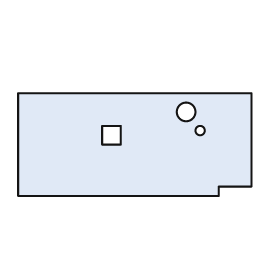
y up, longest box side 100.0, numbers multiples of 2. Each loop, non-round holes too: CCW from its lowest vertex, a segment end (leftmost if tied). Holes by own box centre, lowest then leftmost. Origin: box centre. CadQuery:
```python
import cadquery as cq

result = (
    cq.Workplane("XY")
    .moveTo(-50.0, -22.0)
    .lineTo(36.0, -22.0)
    .lineTo(36.0, -18.0)
    .lineTo(50.0, -18.0)
    .lineTo(50.0, 22.0)
    .lineTo(-50.0, 22.0)
    .close()
    .moveTo(-14.0, 0.0)
    .lineTo(-6.0, 0.0)
    .lineTo(-6.0, 8.0)
    .lineTo(-14.0, 8.0)
    .close()
    .moveTo(28.0, 6.0)
    .circle(2.0)
    .moveTo(22.0, 14.0)
    .circle(4.0)
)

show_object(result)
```